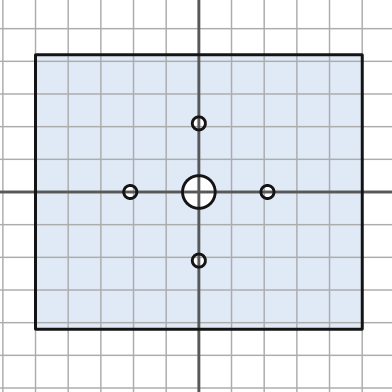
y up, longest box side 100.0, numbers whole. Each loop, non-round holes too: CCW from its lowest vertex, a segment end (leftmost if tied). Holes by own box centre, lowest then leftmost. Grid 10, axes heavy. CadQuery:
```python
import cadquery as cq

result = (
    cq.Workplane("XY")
    .moveTo(-50.0, -42.0)
    .lineTo(50.0, -42.0)
    .lineTo(50.0, 42.0)
    .lineTo(-50.0, 42.0)
    .close()
    .moveTo(0.0, -21.0)
    .circle(2.0)
    .moveTo(-21.0, 0.0)
    .circle(2.0)
    .moveTo(0.0, 0.0)
    .circle(5.0)
    .moveTo(21.0, 0.0)
    .circle(2.0)
    .moveTo(0.0, 21.0)
    .circle(2.0)
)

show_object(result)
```